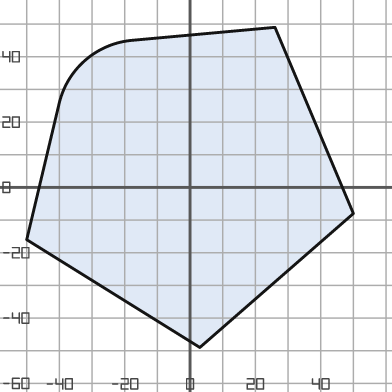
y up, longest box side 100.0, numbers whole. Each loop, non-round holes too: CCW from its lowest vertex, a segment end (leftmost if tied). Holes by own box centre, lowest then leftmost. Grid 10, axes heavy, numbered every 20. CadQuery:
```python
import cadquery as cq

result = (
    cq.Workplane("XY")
    .moveTo(3.0, -49.0)
    .lineTo(50.0, -8.0)
    .lineTo(26.0, 49.0)
    .lineTo(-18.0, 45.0)
    .threePointArc((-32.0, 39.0), (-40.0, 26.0))
    .lineTo(-50.0, -16.0)
    .close()
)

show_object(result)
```